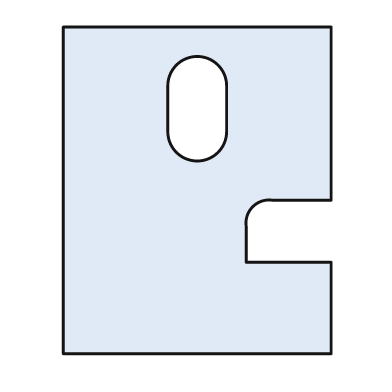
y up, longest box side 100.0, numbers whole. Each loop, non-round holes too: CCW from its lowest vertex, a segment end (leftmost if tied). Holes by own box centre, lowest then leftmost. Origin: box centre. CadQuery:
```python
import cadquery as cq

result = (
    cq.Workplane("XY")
    .moveTo(-41.0, -50.0)
    .lineTo(41.0, -50.0)
    .lineTo(41.0, -22.0)
    .lineTo(15.0, -22.0)
    .lineTo(15.0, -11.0)
    .threePointArc((17.0, -5.0), (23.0, -3.0))
    .lineTo(41.0, -3.0)
    .lineTo(41.0, 50.0)
    .lineTo(-41.0, 50.0)
    .close()
    .moveTo(-9.0, 18.0)
    .threePointArc((0.0, 9.0), (9.0, 18.0))
    .lineTo(9.0, 32.0)
    .threePointArc((0.0, 41.0), (-9.0, 32.0))
    .close()
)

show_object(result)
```